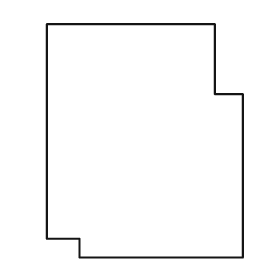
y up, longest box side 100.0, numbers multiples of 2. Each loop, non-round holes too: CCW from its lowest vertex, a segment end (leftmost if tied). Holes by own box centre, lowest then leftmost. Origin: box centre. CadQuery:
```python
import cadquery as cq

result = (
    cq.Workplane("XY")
    .moveTo(-28.0, -50.0)
    .lineTo(42.0, -50.0)
    .lineTo(42.0, 20.0)
    .lineTo(30.0, 20.0)
    .lineTo(30.0, 50.0)
    .lineTo(-42.0, 50.0)
    .lineTo(-42.0, -42.0)
    .lineTo(-28.0, -42.0)
    .close()
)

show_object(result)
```